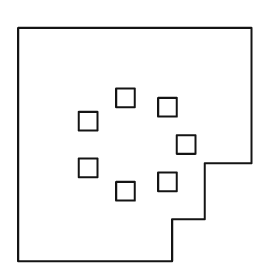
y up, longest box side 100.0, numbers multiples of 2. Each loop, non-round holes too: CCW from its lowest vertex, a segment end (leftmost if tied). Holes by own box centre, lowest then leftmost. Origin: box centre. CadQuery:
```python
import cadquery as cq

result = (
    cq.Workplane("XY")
    .moveTo(-50.0, -50.0)
    .lineTo(16.0, -50.0)
    .lineTo(16.0, -32.0)
    .lineTo(30.0, -32.0)
    .lineTo(30.0, -8.0)
    .lineTo(50.0, -8.0)
    .lineTo(50.0, 50.0)
    .lineTo(-50.0, 50.0)
    .close()
    .moveTo(-8.0, -24.0)
    .lineTo(0.0, -24.0)
    .lineTo(0.0, -16.0)
    .lineTo(-8.0, -16.0)
    .close()
    .moveTo(10.0, -20.0)
    .lineTo(18.0, -20.0)
    .lineTo(18.0, -12.0)
    .lineTo(10.0, -12.0)
    .close()
    .moveTo(-24.0, -14.0)
    .lineTo(-16.0, -14.0)
    .lineTo(-16.0, -6.0)
    .lineTo(-24.0, -6.0)
    .close()
    .moveTo(18.0, -4.0)
    .lineTo(26.0, -4.0)
    .lineTo(26.0, 4.0)
    .lineTo(18.0, 4.0)
    .close()
    .moveTo(-24.0, 6.0)
    .lineTo(-16.0, 6.0)
    .lineTo(-16.0, 14.0)
    .lineTo(-24.0, 14.0)
    .close()
    .moveTo(10.0, 12.0)
    .lineTo(18.0, 12.0)
    .lineTo(18.0, 20.0)
    .lineTo(10.0, 20.0)
    .close()
    .moveTo(-8.0, 16.0)
    .lineTo(0.0, 16.0)
    .lineTo(0.0, 24.0)
    .lineTo(-8.0, 24.0)
    .close()
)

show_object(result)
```